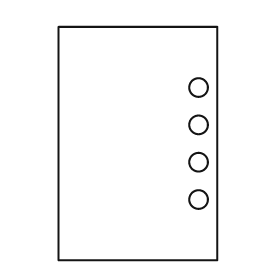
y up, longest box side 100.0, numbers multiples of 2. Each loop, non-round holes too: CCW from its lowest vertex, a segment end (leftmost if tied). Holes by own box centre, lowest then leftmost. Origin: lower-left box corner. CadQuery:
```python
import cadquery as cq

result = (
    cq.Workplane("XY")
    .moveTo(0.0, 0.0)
    .lineTo(68.0, 0.0)
    .lineTo(68.0, 100.0)
    .lineTo(0.0, 100.0)
    .close()
    .moveTo(60.0, 26.0)
    .circle(4.0)
    .moveTo(60.0, 42.0)
    .circle(4.0)
    .moveTo(60.0, 58.0)
    .circle(4.0)
    .moveTo(60.0, 74.0)
    .circle(4.0)
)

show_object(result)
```